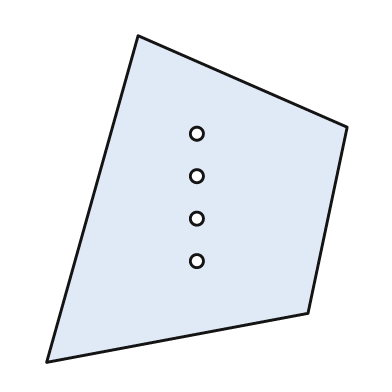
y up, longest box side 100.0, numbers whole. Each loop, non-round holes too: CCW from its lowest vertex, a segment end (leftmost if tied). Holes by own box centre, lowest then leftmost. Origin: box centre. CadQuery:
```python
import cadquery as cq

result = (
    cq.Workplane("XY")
    .moveTo(-46.0, -50.0)
    .lineTo(34.0, -35.0)
    .lineTo(46.0, 22.0)
    .lineTo(-18.0, 50.0)
    .close()
    .moveTo(0.0, -19.0)
    .circle(2.0)
    .moveTo(0.0, -6.0)
    .circle(2.0)
    .moveTo(0.0, 7.0)
    .circle(2.0)
    .moveTo(0.0, 20.0)
    .circle(2.0)
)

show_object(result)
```